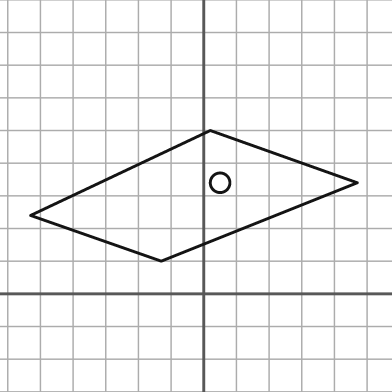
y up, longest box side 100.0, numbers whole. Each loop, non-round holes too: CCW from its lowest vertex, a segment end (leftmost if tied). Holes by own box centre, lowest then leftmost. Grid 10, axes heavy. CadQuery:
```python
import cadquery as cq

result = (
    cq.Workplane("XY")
    .moveTo(-13.0, 10.0)
    .lineTo(47.0, 34.0)
    .lineTo(2.0, 50.0)
    .lineTo(-53.0, 24.0)
    .close()
    .moveTo(5.0, 34.0)
    .circle(3.0)
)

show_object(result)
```